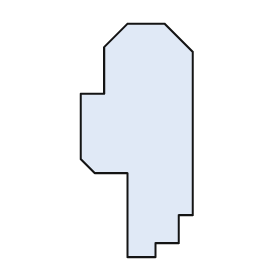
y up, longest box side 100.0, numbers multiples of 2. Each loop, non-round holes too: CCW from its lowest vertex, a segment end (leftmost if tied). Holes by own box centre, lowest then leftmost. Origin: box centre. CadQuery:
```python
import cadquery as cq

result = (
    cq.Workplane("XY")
    .moveTo(-4.0, -50.0)
    .lineTo(8.0, -50.0)
    .lineTo(8.0, -44.0)
    .lineTo(18.0, -44.0)
    .lineTo(18.0, -32.0)
    .lineTo(24.0, -32.0)
    .lineTo(24.0, 38.0)
    .lineTo(12.0, 50.0)
    .lineTo(-4.0, 50.0)
    .lineTo(-14.0, 40.0)
    .lineTo(-14.0, 20.0)
    .lineTo(-24.0, 20.0)
    .lineTo(-24.0, -8.0)
    .lineTo(-18.0, -14.0)
    .lineTo(-4.0, -14.0)
    .close()
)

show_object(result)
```